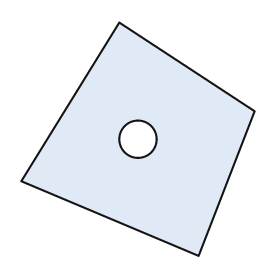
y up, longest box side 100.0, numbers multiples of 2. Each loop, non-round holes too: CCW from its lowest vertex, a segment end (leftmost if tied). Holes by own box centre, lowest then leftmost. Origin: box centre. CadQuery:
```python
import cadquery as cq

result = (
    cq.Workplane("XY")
    .moveTo(26.0, -50.0)
    .lineTo(50.0, 12.0)
    .lineTo(-8.0, 50.0)
    .lineTo(-50.0, -18.0)
    .close()
    .moveTo(0.0, 0.0)
    .circle(8.0)
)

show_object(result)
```